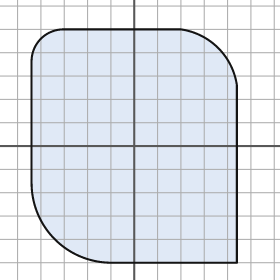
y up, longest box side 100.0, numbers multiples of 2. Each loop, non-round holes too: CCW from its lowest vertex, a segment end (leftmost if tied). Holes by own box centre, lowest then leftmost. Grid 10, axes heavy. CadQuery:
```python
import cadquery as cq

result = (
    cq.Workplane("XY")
    .moveTo(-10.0, -50.0)
    .lineTo(44.0, -50.0)
    .lineTo(44.0, 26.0)
    .threePointArc((36.0, 42.0), (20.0, 50.0))
    .lineTo(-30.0, 50.0)
    .threePointArc((-40.0, 46.0), (-44.0, 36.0))
    .lineTo(-44.0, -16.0)
    .threePointArc((-34.0, -40.0), (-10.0, -50.0))
    .close()
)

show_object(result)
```